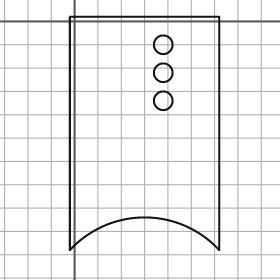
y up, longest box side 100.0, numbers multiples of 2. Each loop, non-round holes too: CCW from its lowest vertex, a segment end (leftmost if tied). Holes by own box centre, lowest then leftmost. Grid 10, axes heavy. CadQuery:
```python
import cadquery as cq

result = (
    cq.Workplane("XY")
    .moveTo(-2.0, -98.0)
    .threePointArc((30.0, -84.0), (62.0, -98.0))
    .lineTo(62.0, 2.0)
    .lineTo(-2.0, 2.0)
    .close()
    .moveTo(38.0, -34.0)
    .circle(4.0)
    .moveTo(38.0, -22.0)
    .circle(4.0)
    .moveTo(38.0, -10.0)
    .circle(4.0)
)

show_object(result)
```